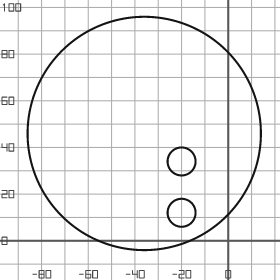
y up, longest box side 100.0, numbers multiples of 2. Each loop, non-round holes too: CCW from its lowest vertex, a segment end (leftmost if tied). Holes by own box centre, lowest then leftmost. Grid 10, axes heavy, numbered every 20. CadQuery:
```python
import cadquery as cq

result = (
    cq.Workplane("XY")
    .moveTo(-36.0, 46.0)
    .circle(50.0)
    .moveTo(-20.0, 12.0)
    .circle(6.0)
    .moveTo(-20.0, 34.0)
    .circle(6.0)
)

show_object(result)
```